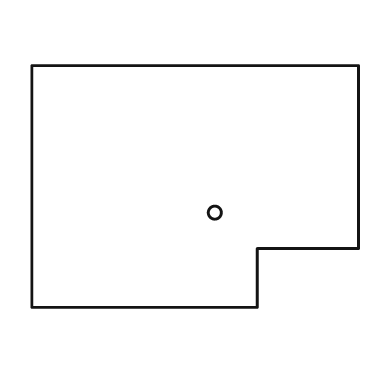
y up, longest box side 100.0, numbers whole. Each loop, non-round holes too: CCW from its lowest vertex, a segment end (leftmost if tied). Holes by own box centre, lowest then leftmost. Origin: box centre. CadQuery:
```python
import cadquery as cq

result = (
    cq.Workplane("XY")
    .moveTo(-50.0, -37.0)
    .lineTo(19.0, -37.0)
    .lineTo(19.0, -19.0)
    .lineTo(50.0, -19.0)
    .lineTo(50.0, 37.0)
    .lineTo(-50.0, 37.0)
    .close()
    .moveTo(6.0, -8.0)
    .circle(2.0)
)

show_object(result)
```